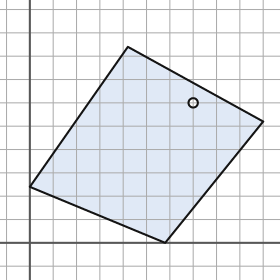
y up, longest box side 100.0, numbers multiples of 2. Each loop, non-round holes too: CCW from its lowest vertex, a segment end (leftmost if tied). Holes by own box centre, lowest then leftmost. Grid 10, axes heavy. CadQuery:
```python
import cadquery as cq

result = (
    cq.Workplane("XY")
    .moveTo(58.0, 0.0)
    .lineTo(100.0, 52.0)
    .lineTo(42.0, 84.0)
    .lineTo(0.0, 24.0)
    .close()
    .moveTo(70.0, 60.0)
    .circle(2.0)
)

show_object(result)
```